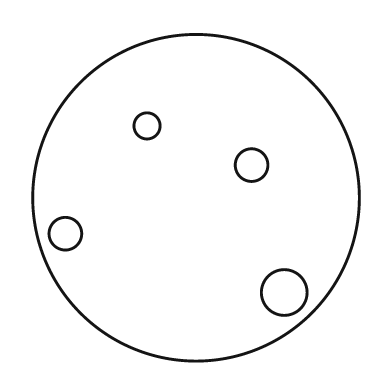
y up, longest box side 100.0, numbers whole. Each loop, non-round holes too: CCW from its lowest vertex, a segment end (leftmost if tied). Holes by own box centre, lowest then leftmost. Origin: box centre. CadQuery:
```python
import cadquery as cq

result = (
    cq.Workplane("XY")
    .moveTo(0.0, 0.0)
    .circle(50.0)
    .moveTo(27.0, -29.0)
    .circle(7.0)
    .moveTo(-40.0, -11.0)
    .circle(5.0)
    .moveTo(17.0, 10.0)
    .circle(5.0)
    .moveTo(-15.0, 22.0)
    .circle(4.0)
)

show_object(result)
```